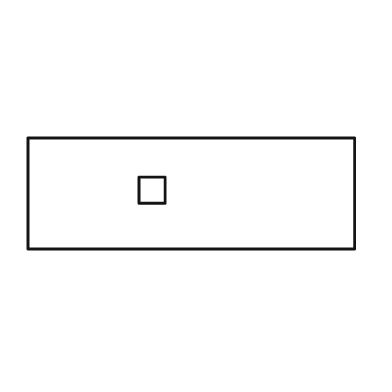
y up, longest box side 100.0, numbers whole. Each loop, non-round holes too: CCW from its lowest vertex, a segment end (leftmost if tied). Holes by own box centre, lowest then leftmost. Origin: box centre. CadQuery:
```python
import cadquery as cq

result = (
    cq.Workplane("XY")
    .moveTo(-50.0, -17.0)
    .lineTo(50.0, -17.0)
    .lineTo(50.0, 17.0)
    .lineTo(-50.0, 17.0)
    .close()
    .moveTo(-16.0, -3.0)
    .lineTo(-8.0, -3.0)
    .lineTo(-8.0, 5.0)
    .lineTo(-16.0, 5.0)
    .close()
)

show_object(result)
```